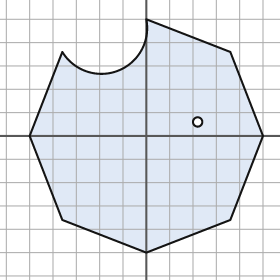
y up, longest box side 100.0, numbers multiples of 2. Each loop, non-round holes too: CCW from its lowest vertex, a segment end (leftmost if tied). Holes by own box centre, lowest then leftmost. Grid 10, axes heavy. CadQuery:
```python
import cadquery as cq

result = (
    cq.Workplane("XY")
    .moveTo(0.0, -50.0)
    .lineTo(36.0, -36.0)
    .lineTo(50.0, 0.0)
    .lineTo(36.0, 36.0)
    .lineTo(0.0, 50.0)
    .threePointArc((-12.0, 28.0), (-36.0, 36.0))
    .lineTo(-50.0, 0.0)
    .lineTo(-36.0, -36.0)
    .close()
    .moveTo(22.0, 6.0)
    .circle(2.0)
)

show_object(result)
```